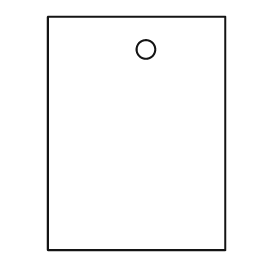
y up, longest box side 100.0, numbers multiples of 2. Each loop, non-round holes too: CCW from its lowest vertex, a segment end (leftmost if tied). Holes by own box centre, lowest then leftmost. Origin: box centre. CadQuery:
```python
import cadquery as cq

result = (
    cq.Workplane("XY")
    .moveTo(-38.0, -50.0)
    .lineTo(38.0, -50.0)
    .lineTo(38.0, 50.0)
    .lineTo(-38.0, 50.0)
    .close()
    .moveTo(4.0, 36.0)
    .circle(4.0)
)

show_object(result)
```